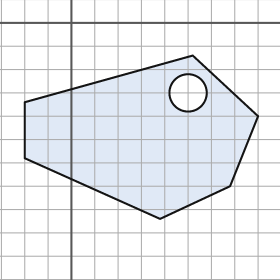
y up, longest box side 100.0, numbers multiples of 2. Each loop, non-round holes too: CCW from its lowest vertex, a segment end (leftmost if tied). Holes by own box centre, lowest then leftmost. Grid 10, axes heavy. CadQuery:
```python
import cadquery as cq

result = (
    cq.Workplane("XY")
    .moveTo(38.0, -84.0)
    .lineTo(68.0, -70.0)
    .lineTo(80.0, -40.0)
    .lineTo(52.0, -14.0)
    .lineTo(-20.0, -34.0)
    .lineTo(-20.0, -58.0)
    .close()
    .moveTo(50.0, -30.0)
    .circle(8.0)
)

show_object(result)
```